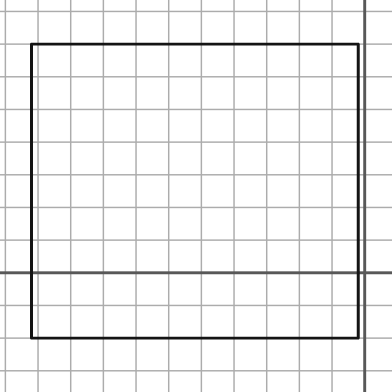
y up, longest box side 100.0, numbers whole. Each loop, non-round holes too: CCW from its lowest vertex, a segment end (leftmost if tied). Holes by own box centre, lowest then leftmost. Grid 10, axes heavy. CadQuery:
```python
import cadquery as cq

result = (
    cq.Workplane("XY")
    .moveTo(-102.0, -20.0)
    .lineTo(-2.0, -20.0)
    .lineTo(-2.0, 70.0)
    .lineTo(-102.0, 70.0)
    .close()
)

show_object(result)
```